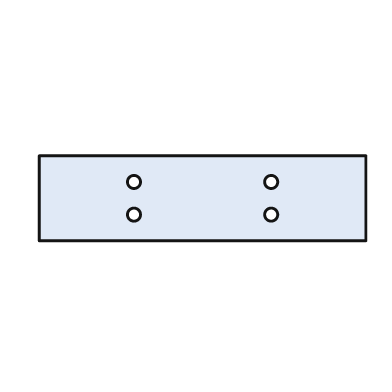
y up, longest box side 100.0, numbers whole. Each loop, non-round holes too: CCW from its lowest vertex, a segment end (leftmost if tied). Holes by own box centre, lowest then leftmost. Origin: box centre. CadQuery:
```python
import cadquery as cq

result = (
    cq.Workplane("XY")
    .moveTo(-50.0, -13.0)
    .lineTo(50.0, -13.0)
    .lineTo(50.0, 13.0)
    .lineTo(-50.0, 13.0)
    .close()
    .moveTo(-21.0, -5.0)
    .circle(2.0)
    .moveTo(21.0, -5.0)
    .circle(2.0)
    .moveTo(-21.0, 5.0)
    .circle(2.0)
    .moveTo(21.0, 5.0)
    .circle(2.0)
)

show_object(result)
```